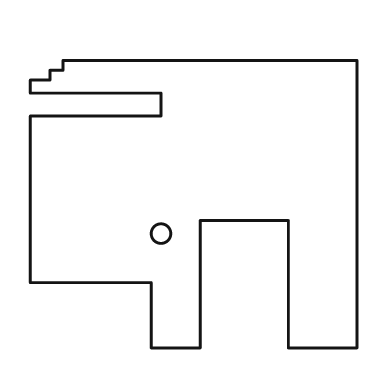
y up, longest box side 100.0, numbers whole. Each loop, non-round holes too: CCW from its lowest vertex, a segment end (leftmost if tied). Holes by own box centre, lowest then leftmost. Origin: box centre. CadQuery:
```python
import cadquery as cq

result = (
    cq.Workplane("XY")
    .moveTo(-13.0, -44.0)
    .lineTo(2.0, -44.0)
    .lineTo(2.0, -5.0)
    .lineTo(29.0, -5.0)
    .lineTo(29.0, -44.0)
    .lineTo(50.0, -44.0)
    .lineTo(50.0, 44.0)
    .lineTo(-40.0, 44.0)
    .lineTo(-40.0, 41.0)
    .lineTo(-44.0, 41.0)
    .lineTo(-44.0, 38.0)
    .lineTo(-50.0, 38.0)
    .lineTo(-50.0, 34.0)
    .lineTo(-10.0, 34.0)
    .lineTo(-10.0, 27.0)
    .lineTo(-50.0, 27.0)
    .lineTo(-50.0, -24.0)
    .lineTo(-13.0, -24.0)
    .close()
    .moveTo(-10.0, -9.0)
    .circle(3.0)
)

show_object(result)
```